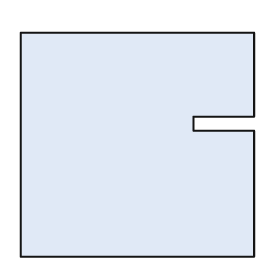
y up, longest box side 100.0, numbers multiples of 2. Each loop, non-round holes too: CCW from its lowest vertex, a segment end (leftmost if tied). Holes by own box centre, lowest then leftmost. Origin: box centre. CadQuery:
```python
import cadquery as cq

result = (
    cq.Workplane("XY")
    .moveTo(-50.0, -48.0)
    .lineTo(50.0, -48.0)
    .lineTo(50.0, 6.0)
    .lineTo(24.0, 6.0)
    .lineTo(24.0, 12.0)
    .lineTo(50.0, 12.0)
    .lineTo(50.0, 48.0)
    .lineTo(-50.0, 48.0)
    .close()
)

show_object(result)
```